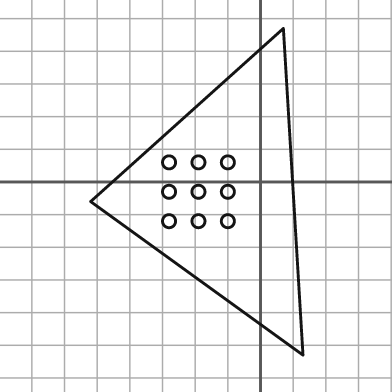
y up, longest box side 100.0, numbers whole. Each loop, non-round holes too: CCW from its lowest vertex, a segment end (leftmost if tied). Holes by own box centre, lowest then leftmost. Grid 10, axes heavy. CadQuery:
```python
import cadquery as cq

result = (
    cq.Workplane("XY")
    .moveTo(13.0, -53.0)
    .lineTo(7.0, 47.0)
    .lineTo(-52.0, -6.0)
    .close()
    .moveTo(-28.0, -12.0)
    .circle(2.0)
    .moveTo(-19.0, -12.0)
    .circle(2.0)
    .moveTo(-10.0, -12.0)
    .circle(2.0)
    .moveTo(-28.0, -3.0)
    .circle(2.0)
    .moveTo(-19.0, -3.0)
    .circle(2.0)
    .moveTo(-10.0, -3.0)
    .circle(2.0)
    .moveTo(-28.0, 6.0)
    .circle(2.0)
    .moveTo(-19.0, 6.0)
    .circle(2.0)
    .moveTo(-10.0, 6.0)
    .circle(2.0)
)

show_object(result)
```